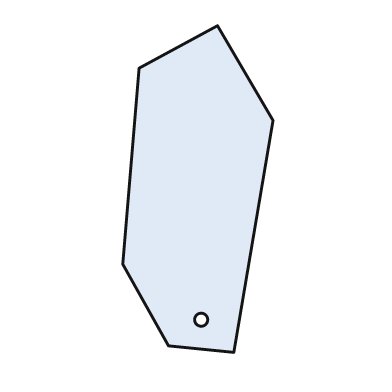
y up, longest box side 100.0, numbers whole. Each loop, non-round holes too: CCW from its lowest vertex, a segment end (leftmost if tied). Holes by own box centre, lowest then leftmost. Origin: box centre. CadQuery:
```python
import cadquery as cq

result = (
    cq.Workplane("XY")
    .moveTo(11.0, -50.0)
    .lineTo(23.0, 21.0)
    .lineTo(6.0, 50.0)
    .lineTo(-18.0, 37.0)
    .lineTo(-23.0, -23.0)
    .lineTo(-9.0, -48.0)
    .close()
    .moveTo(1.0, -40.0)
    .circle(2.0)
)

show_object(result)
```